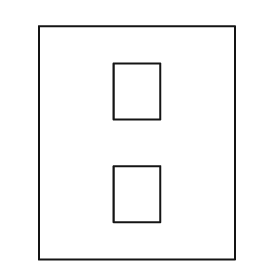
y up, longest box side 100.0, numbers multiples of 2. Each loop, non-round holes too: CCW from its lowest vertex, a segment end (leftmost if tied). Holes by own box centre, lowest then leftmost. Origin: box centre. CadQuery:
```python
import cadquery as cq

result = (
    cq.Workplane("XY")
    .moveTo(-42.0, -50.0)
    .lineTo(42.0, -50.0)
    .lineTo(42.0, 50.0)
    .lineTo(-42.0, 50.0)
    .close()
    .moveTo(-10.0, -34.0)
    .lineTo(10.0, -34.0)
    .lineTo(10.0, -10.0)
    .lineTo(-10.0, -10.0)
    .close()
    .moveTo(-10.0, 10.0)
    .lineTo(10.0, 10.0)
    .lineTo(10.0, 34.0)
    .lineTo(-10.0, 34.0)
    .close()
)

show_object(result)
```